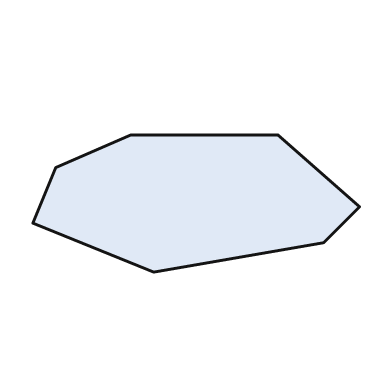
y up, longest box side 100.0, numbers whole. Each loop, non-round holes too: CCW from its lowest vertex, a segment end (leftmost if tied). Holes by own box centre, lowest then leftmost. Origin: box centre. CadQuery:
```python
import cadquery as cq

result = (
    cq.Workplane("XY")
    .moveTo(-13.0, -21.0)
    .lineTo(39.0, -12.0)
    .lineTo(50.0, -1.0)
    .lineTo(25.0, 21.0)
    .lineTo(-20.0, 21.0)
    .lineTo(-43.0, 11.0)
    .lineTo(-50.0, -6.0)
    .close()
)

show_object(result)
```